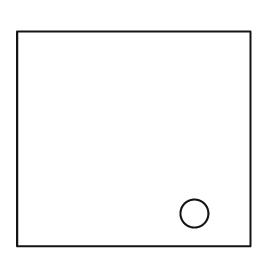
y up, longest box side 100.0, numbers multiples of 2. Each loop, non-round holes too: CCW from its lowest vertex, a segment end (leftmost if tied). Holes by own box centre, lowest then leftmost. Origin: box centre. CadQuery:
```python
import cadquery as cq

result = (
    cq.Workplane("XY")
    .moveTo(-50.0, -46.0)
    .lineTo(50.0, -46.0)
    .lineTo(50.0, 46.0)
    .lineTo(-50.0, 46.0)
    .close()
    .moveTo(26.0, -32.0)
    .circle(6.0)
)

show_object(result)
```